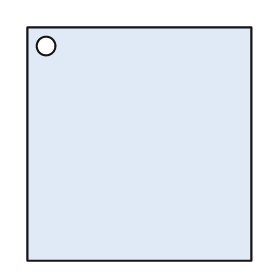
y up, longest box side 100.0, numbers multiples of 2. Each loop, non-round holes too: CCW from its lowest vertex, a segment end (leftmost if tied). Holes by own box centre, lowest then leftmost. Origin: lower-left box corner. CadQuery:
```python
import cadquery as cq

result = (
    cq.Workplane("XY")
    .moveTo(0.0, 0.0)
    .lineTo(96.0, 0.0)
    .lineTo(96.0, 100.0)
    .lineTo(0.0, 100.0)
    .close()
    .moveTo(8.0, 92.0)
    .circle(4.0)
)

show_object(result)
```